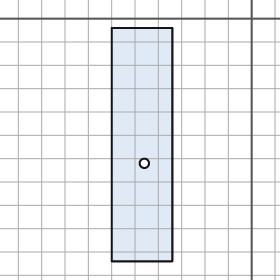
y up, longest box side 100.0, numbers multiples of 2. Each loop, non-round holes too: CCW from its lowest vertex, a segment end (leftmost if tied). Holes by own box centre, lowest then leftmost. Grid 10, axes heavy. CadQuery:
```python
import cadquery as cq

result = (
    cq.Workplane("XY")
    .moveTo(-60.0, -104.0)
    .lineTo(-34.0, -104.0)
    .lineTo(-34.0, -4.0)
    .lineTo(-60.0, -4.0)
    .close()
    .moveTo(-46.0, -62.0)
    .circle(2.0)
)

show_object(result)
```